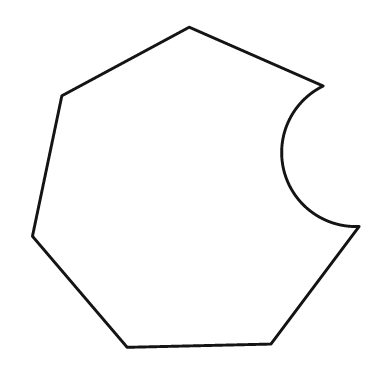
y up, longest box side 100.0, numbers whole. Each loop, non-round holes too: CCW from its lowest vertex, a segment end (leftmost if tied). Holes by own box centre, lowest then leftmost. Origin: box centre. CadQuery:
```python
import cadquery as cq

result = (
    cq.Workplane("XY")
    .moveTo(-21.0, -49.0)
    .lineTo(23.0, -48.0)
    .lineTo(50.0, -12.0)
    .threePointArc((27.0, 5.0), (39.0, 31.0))
    .lineTo(-2.0, 49.0)
    .lineTo(-41.0, 28.0)
    .lineTo(-50.0, -15.0)
    .close()
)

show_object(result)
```